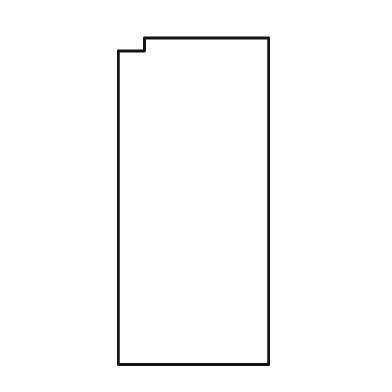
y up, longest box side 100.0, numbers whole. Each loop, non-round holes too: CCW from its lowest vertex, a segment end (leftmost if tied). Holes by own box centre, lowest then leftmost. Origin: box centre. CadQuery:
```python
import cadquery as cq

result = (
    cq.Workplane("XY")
    .moveTo(-23.0, -50.0)
    .lineTo(23.0, -50.0)
    .lineTo(23.0, 50.0)
    .lineTo(-15.0, 50.0)
    .lineTo(-15.0, 46.0)
    .lineTo(-23.0, 46.0)
    .close()
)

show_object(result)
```